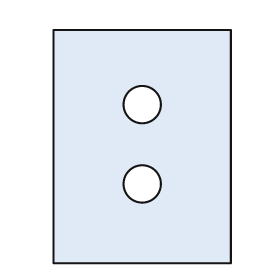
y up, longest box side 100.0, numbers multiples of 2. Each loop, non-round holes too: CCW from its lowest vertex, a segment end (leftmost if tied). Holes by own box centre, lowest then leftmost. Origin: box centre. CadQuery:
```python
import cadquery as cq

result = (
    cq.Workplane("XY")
    .moveTo(-38.0, -50.0)
    .lineTo(38.0, -50.0)
    .lineTo(38.0, 50.0)
    .lineTo(-38.0, 50.0)
    .close()
    .moveTo(0.0, -16.0)
    .circle(8.0)
    .moveTo(0.0, 18.0)
    .circle(8.0)
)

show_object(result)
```